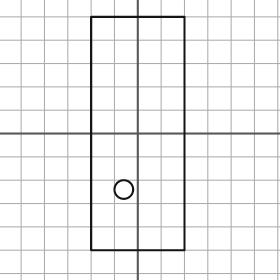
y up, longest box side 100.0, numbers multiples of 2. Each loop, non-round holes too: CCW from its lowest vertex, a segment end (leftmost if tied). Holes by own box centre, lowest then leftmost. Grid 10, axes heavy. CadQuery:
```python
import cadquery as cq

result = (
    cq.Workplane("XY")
    .moveTo(-20.0, -50.0)
    .lineTo(20.0, -50.0)
    .lineTo(20.0, 50.0)
    .lineTo(-20.0, 50.0)
    .close()
    .moveTo(-6.0, -24.0)
    .circle(4.0)
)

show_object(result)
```